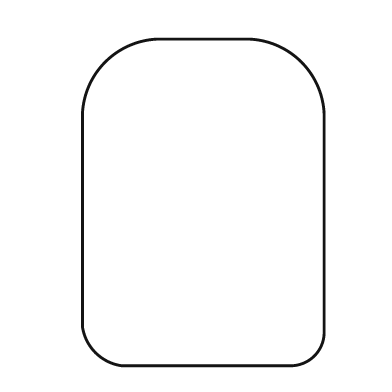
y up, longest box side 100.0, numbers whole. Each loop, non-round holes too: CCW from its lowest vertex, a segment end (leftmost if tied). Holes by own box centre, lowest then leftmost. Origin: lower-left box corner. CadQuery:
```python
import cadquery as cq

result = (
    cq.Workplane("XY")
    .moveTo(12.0, 0.0)
    .lineTo(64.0, 0.0)
    .threePointArc((71.0, 3.0), (74.0, 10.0))
    .lineTo(74.0, 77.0)
    .threePointArc((67.0, 93.0), (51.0, 100.0))
    .lineTo(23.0, 100.0)
    .threePointArc((7.0, 93.0), (0.0, 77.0))
    .lineTo(0.0, 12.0)
    .threePointArc((4.0, 4.0), (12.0, 0.0))
    .close()
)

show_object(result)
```